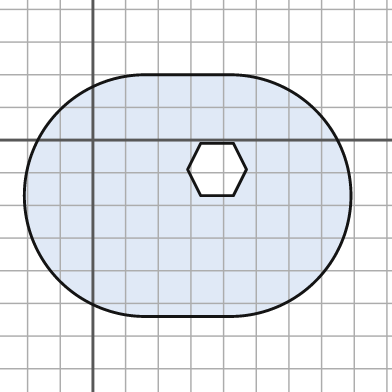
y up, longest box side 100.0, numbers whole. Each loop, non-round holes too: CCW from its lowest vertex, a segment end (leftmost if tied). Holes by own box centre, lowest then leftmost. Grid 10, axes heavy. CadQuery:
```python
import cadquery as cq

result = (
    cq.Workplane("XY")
    .moveTo(16.0, -54.0)
    .lineTo(42.0, -54.0)
    .threePointArc((79.0, -17.0), (42.0, 20.0))
    .lineTo(16.0, 20.0)
    .threePointArc((-21.0, -17.0), (16.0, -54.0))
    .close()
    .moveTo(33.0, -17.0)
    .lineTo(43.0, -17.0)
    .lineTo(47.0, -9.0)
    .lineTo(43.0, -1.0)
    .lineTo(33.0, -1.0)
    .lineTo(29.0, -9.0)
    .close()
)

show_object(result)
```